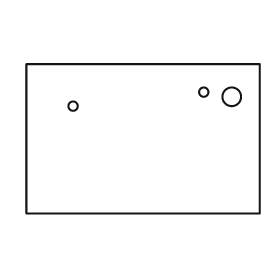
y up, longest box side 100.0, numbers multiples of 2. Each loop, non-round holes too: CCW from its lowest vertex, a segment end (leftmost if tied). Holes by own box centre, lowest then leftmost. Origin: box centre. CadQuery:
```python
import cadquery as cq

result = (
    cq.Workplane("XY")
    .moveTo(-50.0, -32.0)
    .lineTo(50.0, -32.0)
    .lineTo(50.0, 32.0)
    .lineTo(-50.0, 32.0)
    .close()
    .moveTo(-30.0, 14.0)
    .circle(2.0)
    .moveTo(38.0, 18.0)
    .circle(4.0)
    .moveTo(26.0, 20.0)
    .circle(2.0)
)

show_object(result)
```